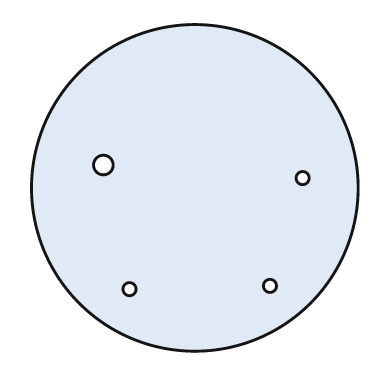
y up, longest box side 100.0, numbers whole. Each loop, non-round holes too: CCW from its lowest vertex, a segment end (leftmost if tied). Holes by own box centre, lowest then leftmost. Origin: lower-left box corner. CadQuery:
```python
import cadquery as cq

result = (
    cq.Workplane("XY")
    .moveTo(50.0, 50.0)
    .circle(50.0)
    .moveTo(30.0, 19.0)
    .circle(2.0)
    .moveTo(73.0, 20.0)
    .circle(2.0)
    .moveTo(83.0, 53.0)
    .circle(2.0)
    .moveTo(22.0, 57.0)
    .circle(3.0)
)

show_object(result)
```